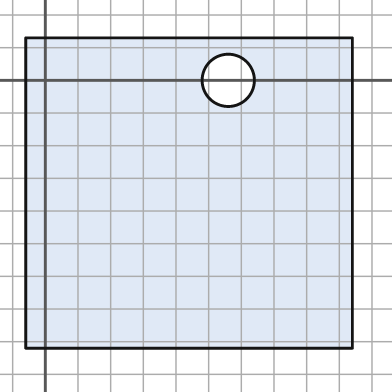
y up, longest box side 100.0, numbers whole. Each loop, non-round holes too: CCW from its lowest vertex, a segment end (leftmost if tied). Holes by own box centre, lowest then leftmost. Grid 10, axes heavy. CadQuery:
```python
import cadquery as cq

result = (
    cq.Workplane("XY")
    .moveTo(-6.0, -82.0)
    .lineTo(94.0, -82.0)
    .lineTo(94.0, 13.0)
    .lineTo(-6.0, 13.0)
    .close()
    .moveTo(56.0, 0.0)
    .circle(8.0)
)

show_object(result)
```